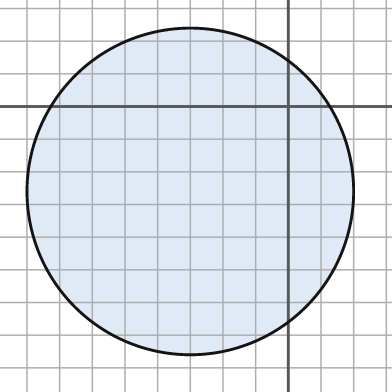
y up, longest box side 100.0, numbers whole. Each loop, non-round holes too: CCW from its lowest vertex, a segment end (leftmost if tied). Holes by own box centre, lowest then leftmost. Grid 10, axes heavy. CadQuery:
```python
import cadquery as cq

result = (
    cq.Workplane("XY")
    .moveTo(-30.0, -26.0)
    .circle(50.0)
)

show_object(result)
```